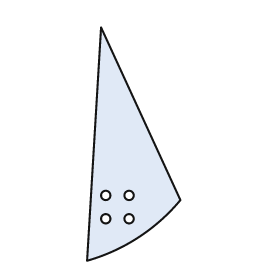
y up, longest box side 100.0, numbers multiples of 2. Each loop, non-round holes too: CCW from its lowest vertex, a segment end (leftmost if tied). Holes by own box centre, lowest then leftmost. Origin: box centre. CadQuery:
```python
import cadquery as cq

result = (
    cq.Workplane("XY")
    .moveTo(-20.0, -50.0)
    .threePointArc((2.0, -40.0), (20.0, -24.0))
    .lineTo(-14.0, 50.0)
    .close()
    .moveTo(-12.0, -32.0)
    .circle(2.0)
    .moveTo(-2.0, -32.0)
    .circle(2.0)
    .moveTo(-12.0, -22.0)
    .circle(2.0)
    .moveTo(-2.0, -22.0)
    .circle(2.0)
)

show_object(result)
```